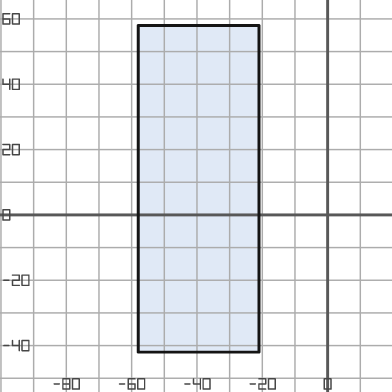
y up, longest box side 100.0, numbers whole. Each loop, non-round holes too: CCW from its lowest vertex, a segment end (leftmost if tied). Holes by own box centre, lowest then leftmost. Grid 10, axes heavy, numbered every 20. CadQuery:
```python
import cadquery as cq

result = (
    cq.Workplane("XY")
    .moveTo(-58.0, -42.0)
    .lineTo(-21.0, -42.0)
    .lineTo(-21.0, 58.0)
    .lineTo(-58.0, 58.0)
    .close()
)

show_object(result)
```